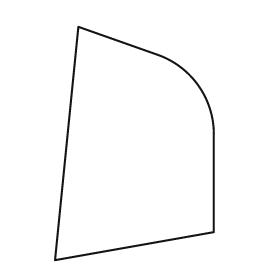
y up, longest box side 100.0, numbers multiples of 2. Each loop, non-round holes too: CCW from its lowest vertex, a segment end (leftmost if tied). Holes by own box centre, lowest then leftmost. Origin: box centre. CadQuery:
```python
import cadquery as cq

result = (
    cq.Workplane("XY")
    .moveTo(-34.0, -50.0)
    .lineTo(34.0, -38.0)
    .lineTo(34.0, 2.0)
    .threePointArc((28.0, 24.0), (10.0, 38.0))
    .lineTo(-24.0, 50.0)
    .close()
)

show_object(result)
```